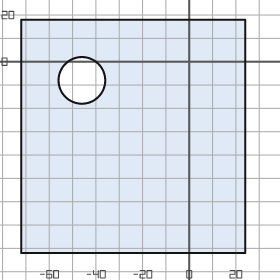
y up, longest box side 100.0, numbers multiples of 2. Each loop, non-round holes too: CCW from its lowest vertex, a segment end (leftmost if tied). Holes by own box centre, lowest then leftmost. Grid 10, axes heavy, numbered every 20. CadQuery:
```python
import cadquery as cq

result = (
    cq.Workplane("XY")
    .moveTo(-72.0, -82.0)
    .lineTo(24.0, -82.0)
    .lineTo(24.0, 18.0)
    .lineTo(-72.0, 18.0)
    .close()
    .moveTo(-46.0, -8.0)
    .circle(10.0)
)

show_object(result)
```